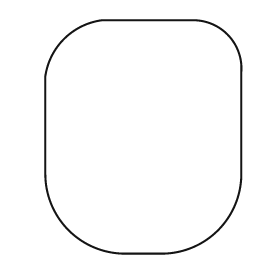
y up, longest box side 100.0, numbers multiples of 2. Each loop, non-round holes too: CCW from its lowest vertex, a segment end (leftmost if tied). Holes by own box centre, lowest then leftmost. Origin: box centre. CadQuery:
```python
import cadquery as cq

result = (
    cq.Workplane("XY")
    .moveTo(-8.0, -50.0)
    .lineTo(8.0, -50.0)
    .threePointArc((32.0, -40.0), (42.0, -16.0))
    .lineTo(42.0, 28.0)
    .threePointArc((36.0, 44.0), (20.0, 50.0))
    .lineTo(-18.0, 50.0)
    .threePointArc((-34.0, 42.0), (-42.0, 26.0))
    .lineTo(-42.0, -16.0)
    .threePointArc((-32.0, -40.0), (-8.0, -50.0))
    .close()
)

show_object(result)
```